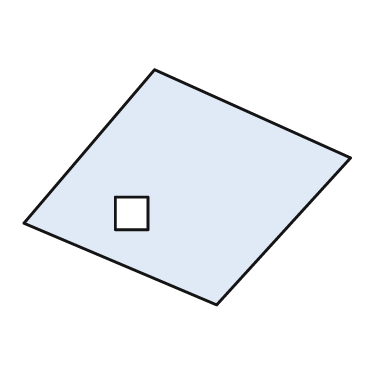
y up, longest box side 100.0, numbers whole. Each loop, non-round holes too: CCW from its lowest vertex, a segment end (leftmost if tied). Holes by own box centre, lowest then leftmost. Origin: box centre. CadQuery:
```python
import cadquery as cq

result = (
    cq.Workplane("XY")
    .moveTo(9.0, -36.0)
    .lineTo(50.0, 9.0)
    .lineTo(-10.0, 36.0)
    .lineTo(-50.0, -11.0)
    .close()
    .moveTo(-22.0, -13.0)
    .lineTo(-12.0, -13.0)
    .lineTo(-12.0, -3.0)
    .lineTo(-22.0, -3.0)
    .close()
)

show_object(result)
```